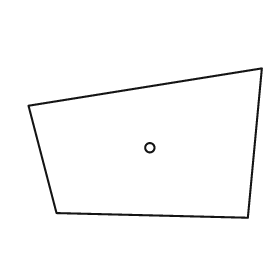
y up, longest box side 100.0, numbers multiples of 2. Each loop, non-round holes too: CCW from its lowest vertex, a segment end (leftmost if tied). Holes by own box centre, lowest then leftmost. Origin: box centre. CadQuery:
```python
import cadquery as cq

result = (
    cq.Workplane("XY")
    .moveTo(44.0, -32.0)
    .lineTo(50.0, 32.0)
    .lineTo(-50.0, 16.0)
    .lineTo(-38.0, -30.0)
    .close()
    .moveTo(2.0, -2.0)
    .circle(2.0)
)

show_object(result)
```